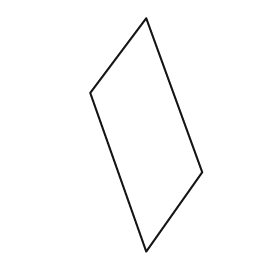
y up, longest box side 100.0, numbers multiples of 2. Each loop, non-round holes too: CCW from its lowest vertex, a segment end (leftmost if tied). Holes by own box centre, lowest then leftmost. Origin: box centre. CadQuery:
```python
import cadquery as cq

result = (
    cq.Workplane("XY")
    .moveTo(0.0, -50.0)
    .lineTo(24.0, -16.0)
    .lineTo(0.0, 50.0)
    .lineTo(-24.0, 18.0)
    .close()
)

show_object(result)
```